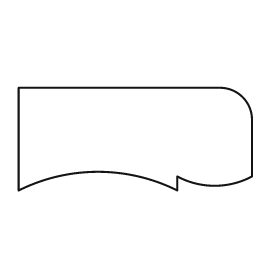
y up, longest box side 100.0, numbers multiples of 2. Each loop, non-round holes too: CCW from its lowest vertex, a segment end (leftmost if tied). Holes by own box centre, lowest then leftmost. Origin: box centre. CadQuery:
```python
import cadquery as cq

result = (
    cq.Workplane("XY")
    .moveTo(-50.0, -22.0)
    .threePointArc((-16.0, -14.0), (18.0, -22.0))
    .lineTo(18.0, -16.0)
    .threePointArc((34.0, -20.0), (50.0, -16.0))
    .lineTo(50.0, 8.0)
    .threePointArc((46.0, 18.0), (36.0, 22.0))
    .lineTo(-50.0, 22.0)
    .close()
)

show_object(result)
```